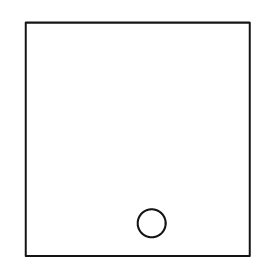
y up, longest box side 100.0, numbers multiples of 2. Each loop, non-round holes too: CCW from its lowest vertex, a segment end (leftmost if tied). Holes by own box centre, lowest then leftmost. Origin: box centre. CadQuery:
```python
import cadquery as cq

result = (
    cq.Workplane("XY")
    .moveTo(-48.0, -50.0)
    .lineTo(48.0, -50.0)
    .lineTo(48.0, 50.0)
    .lineTo(-48.0, 50.0)
    .close()
    .moveTo(6.0, -36.0)
    .circle(6.0)
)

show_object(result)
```